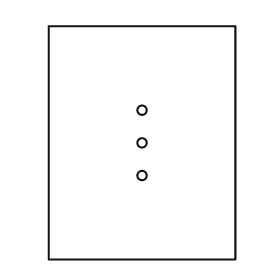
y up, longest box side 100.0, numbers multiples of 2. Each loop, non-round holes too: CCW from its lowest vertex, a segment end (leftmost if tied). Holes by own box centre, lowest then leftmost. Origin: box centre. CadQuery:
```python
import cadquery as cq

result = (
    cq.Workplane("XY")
    .moveTo(-40.0, -50.0)
    .lineTo(40.0, -50.0)
    .lineTo(40.0, 50.0)
    .lineTo(-40.0, 50.0)
    .close()
    .moveTo(0.0, -14.0)
    .circle(2.0)
    .moveTo(0.0, 0.0)
    .circle(2.0)
    .moveTo(0.0, 14.0)
    .circle(2.0)
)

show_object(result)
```